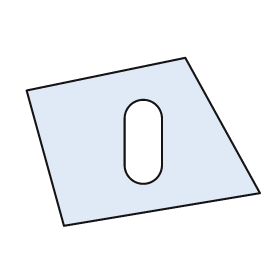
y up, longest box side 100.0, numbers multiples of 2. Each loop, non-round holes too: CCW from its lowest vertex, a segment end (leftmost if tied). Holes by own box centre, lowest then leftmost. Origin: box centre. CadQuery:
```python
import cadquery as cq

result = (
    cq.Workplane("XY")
    .moveTo(-34.0, -36.0)
    .lineTo(50.0, -22.0)
    .lineTo(18.0, 36.0)
    .lineTo(-50.0, 22.0)
    .close()
    .moveTo(-8.0, -10.0)
    .threePointArc((0.0, -18.0), (8.0, -10.0))
    .lineTo(8.0, 10.0)
    .threePointArc((0.0, 18.0), (-8.0, 10.0))
    .close()
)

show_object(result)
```